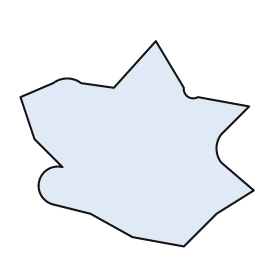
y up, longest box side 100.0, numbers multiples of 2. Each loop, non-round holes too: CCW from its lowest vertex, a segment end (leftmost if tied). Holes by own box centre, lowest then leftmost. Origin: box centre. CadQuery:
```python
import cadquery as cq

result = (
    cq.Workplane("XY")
    .moveTo(20.0, -44.0)
    .lineTo(34.0, -30.0)
    .lineTo(50.0, -20.0)
    .lineTo(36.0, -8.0)
    .threePointArc((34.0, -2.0), (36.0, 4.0))
    .lineTo(48.0, 16.0)
    .lineTo(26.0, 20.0)
    .threePointArc((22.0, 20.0), (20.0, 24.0))
    .lineTo(8.0, 44.0)
    .lineTo(-10.0, 24.0)
    .lineTo(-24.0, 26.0)
    .threePointArc((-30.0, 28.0), (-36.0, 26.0))
    .lineTo(-50.0, 20.0)
    .lineTo(-44.0, 2.0)
    .lineTo(-32.0, -10.0)
    .threePointArc((-42.0, -16.0), (-36.0, -26.0))
    .lineTo(-20.0, -30.0)
    .lineTo(-2.0, -40.0)
    .close()
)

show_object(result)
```